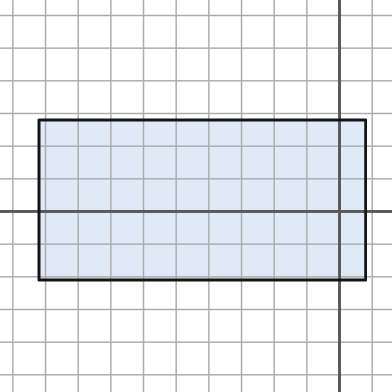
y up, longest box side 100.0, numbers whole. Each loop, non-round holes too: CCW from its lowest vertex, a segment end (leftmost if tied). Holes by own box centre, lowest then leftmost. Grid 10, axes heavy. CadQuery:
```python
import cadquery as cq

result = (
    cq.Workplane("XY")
    .moveTo(-92.0, -21.0)
    .lineTo(8.0, -21.0)
    .lineTo(8.0, 28.0)
    .lineTo(-92.0, 28.0)
    .close()
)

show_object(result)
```